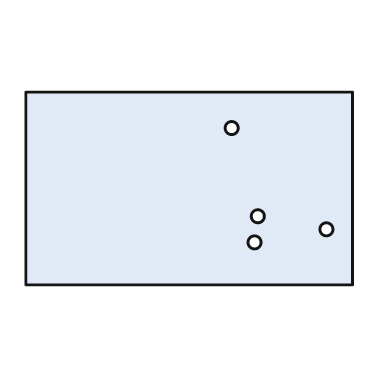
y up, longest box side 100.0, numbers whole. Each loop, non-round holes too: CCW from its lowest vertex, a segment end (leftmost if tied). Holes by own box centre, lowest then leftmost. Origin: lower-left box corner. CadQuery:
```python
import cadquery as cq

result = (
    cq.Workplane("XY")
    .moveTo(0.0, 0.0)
    .lineTo(100.0, 0.0)
    .lineTo(100.0, 59.0)
    .lineTo(0.0, 59.0)
    .close()
    .moveTo(70.0, 13.0)
    .circle(2.0)
    .moveTo(92.0, 17.0)
    .circle(2.0)
    .moveTo(71.0, 21.0)
    .circle(2.0)
    .moveTo(63.0, 48.0)
    .circle(2.0)
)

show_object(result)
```